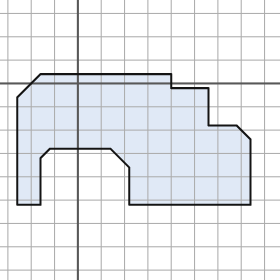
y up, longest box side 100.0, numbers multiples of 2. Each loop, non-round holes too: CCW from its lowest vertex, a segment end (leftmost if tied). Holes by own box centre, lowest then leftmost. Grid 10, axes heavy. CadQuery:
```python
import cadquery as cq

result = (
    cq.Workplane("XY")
    .moveTo(-26.0, -52.0)
    .lineTo(-16.0, -52.0)
    .lineTo(-16.0, -32.0)
    .lineTo(-12.0, -28.0)
    .lineTo(14.0, -28.0)
    .lineTo(22.0, -36.0)
    .lineTo(22.0, -52.0)
    .lineTo(74.0, -52.0)
    .lineTo(74.0, -24.0)
    .lineTo(68.0, -18.0)
    .lineTo(56.0, -18.0)
    .lineTo(56.0, -2.0)
    .lineTo(40.0, -2.0)
    .lineTo(40.0, 4.0)
    .lineTo(-16.0, 4.0)
    .lineTo(-26.0, -6.0)
    .close()
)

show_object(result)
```